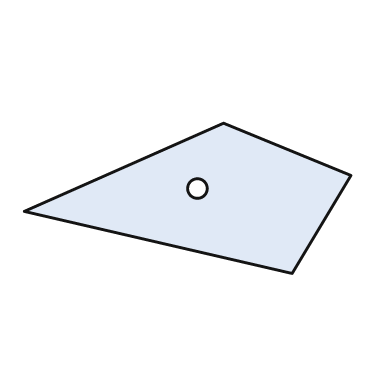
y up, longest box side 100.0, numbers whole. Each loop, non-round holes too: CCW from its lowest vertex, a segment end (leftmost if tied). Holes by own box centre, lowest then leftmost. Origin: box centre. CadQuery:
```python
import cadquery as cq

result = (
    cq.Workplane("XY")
    .moveTo(32.0, -23.0)
    .lineTo(50.0, 7.0)
    .lineTo(11.0, 23.0)
    .lineTo(-50.0, -4.0)
    .close()
    .moveTo(3.0, 3.0)
    .circle(3.0)
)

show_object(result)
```